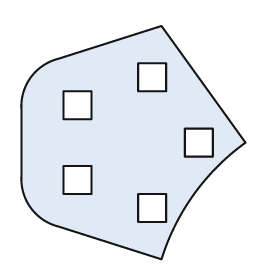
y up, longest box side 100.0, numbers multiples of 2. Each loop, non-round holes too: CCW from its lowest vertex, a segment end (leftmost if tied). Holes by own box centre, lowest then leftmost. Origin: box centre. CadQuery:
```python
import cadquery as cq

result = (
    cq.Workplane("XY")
    .moveTo(12.0, -50.0)
    .threePointArc((26.0, -22.0), (48.0, 0.0))
    .lineTo(12.0, 50.0)
    .lineTo(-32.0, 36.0)
    .threePointArc((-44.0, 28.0), (-48.0, 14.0))
    .lineTo(-48.0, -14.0)
    .threePointArc((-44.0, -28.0), (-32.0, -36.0))
    .close()
    .moveTo(2.0, -34.0)
    .lineTo(14.0, -34.0)
    .lineTo(14.0, -22.0)
    .lineTo(2.0, -22.0)
    .close()
    .moveTo(-30.0, -22.0)
    .lineTo(-18.0, -22.0)
    .lineTo(-18.0, -10.0)
    .lineTo(-30.0, -10.0)
    .close()
    .moveTo(22.0, -6.0)
    .lineTo(34.0, -6.0)
    .lineTo(34.0, 6.0)
    .lineTo(22.0, 6.0)
    .close()
    .moveTo(-30.0, 10.0)
    .lineTo(-18.0, 10.0)
    .lineTo(-18.0, 22.0)
    .lineTo(-30.0, 22.0)
    .close()
    .moveTo(2.0, 22.0)
    .lineTo(14.0, 22.0)
    .lineTo(14.0, 34.0)
    .lineTo(2.0, 34.0)
    .close()
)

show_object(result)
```